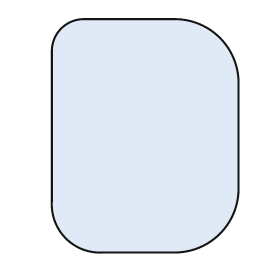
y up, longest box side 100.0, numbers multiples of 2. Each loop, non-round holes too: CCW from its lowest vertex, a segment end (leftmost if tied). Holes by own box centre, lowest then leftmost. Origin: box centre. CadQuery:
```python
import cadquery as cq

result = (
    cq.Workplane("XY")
    .moveTo(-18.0, -50.0)
    .lineTo(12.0, -50.0)
    .threePointArc((32.0, -42.0), (40.0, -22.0))
    .lineTo(40.0, 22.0)
    .threePointArc((32.0, 42.0), (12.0, 50.0))
    .lineTo(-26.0, 50.0)
    .threePointArc((-36.0, 46.0), (-40.0, 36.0))
    .lineTo(-40.0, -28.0)
    .threePointArc((-34.0, -44.0), (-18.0, -50.0))
    .close()
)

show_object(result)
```